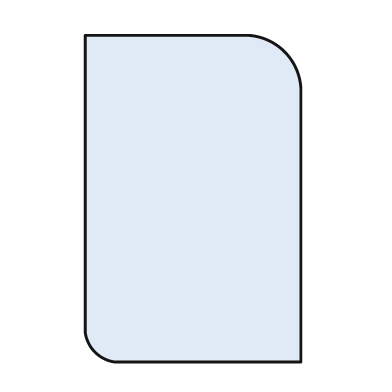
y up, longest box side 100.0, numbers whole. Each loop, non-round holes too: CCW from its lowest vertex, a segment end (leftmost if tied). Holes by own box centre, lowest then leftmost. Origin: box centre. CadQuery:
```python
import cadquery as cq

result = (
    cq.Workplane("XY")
    .moveTo(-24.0, -50.0)
    .lineTo(33.0, -50.0)
    .lineTo(33.0, 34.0)
    .threePointArc((28.0, 45.0), (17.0, 50.0))
    .lineTo(-33.0, 50.0)
    .lineTo(-33.0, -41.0)
    .threePointArc((-30.0, -47.0), (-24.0, -50.0))
    .close()
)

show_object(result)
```